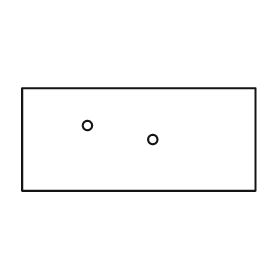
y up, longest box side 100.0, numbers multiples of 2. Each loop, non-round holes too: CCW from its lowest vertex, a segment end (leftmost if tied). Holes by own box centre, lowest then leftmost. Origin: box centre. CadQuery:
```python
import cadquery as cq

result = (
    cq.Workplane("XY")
    .moveTo(-50.0, -22.0)
    .lineTo(50.0, -22.0)
    .lineTo(50.0, 22.0)
    .lineTo(-50.0, 22.0)
    .close()
    .moveTo(6.0, 0.0)
    .circle(2.0)
    .moveTo(-22.0, 6.0)
    .circle(2.0)
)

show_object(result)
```